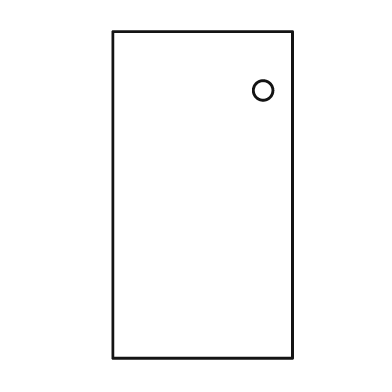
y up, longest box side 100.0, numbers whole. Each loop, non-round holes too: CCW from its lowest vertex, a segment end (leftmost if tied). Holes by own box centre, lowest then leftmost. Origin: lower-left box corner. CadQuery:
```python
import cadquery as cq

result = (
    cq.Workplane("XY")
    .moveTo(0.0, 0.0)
    .lineTo(55.0, 0.0)
    .lineTo(55.0, 100.0)
    .lineTo(0.0, 100.0)
    .close()
    .moveTo(46.0, 82.0)
    .circle(3.0)
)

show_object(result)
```